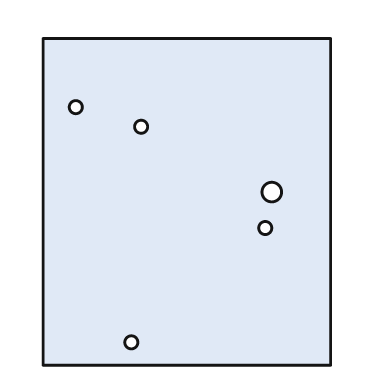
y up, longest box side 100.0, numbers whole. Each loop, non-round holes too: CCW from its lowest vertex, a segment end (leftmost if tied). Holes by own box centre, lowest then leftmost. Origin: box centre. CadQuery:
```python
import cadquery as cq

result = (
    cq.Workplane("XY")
    .moveTo(-44.0, -50.0)
    .lineTo(44.0, -50.0)
    .lineTo(44.0, 50.0)
    .lineTo(-44.0, 50.0)
    .close()
    .moveTo(-17.0, -43.0)
    .circle(2.0)
    .moveTo(24.0, -8.0)
    .circle(2.0)
    .moveTo(26.0, 3.0)
    .circle(3.0)
    .moveTo(-14.0, 23.0)
    .circle(2.0)
    .moveTo(-34.0, 29.0)
    .circle(2.0)
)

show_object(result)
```